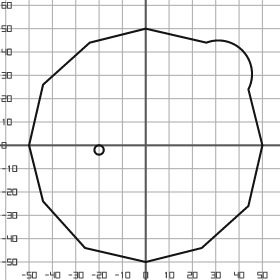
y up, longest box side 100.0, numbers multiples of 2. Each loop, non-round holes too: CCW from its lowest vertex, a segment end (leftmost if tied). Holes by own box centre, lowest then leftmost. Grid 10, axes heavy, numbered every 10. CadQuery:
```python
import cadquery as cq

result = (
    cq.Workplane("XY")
    .moveTo(0.0, -50.0)
    .lineTo(24.0, -44.0)
    .lineTo(44.0, -26.0)
    .lineTo(50.0, 0.0)
    .lineTo(44.0, 24.0)
    .threePointArc((42.0, 40.0), (26.0, 44.0))
    .lineTo(0.0, 50.0)
    .lineTo(-24.0, 44.0)
    .lineTo(-44.0, 26.0)
    .lineTo(-50.0, 0.0)
    .lineTo(-44.0, -24.0)
    .lineTo(-26.0, -44.0)
    .close()
    .moveTo(-20.0, -2.0)
    .circle(2.0)
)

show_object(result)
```